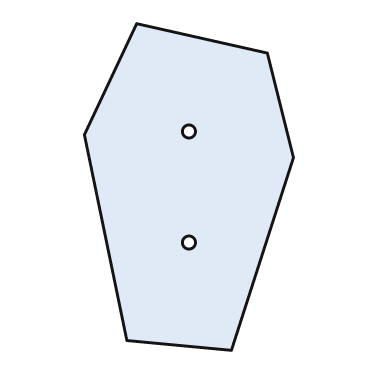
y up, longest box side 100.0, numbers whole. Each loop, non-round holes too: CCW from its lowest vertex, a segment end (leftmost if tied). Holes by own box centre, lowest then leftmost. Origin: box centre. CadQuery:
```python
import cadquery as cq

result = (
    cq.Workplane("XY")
    .moveTo(13.0, -50.0)
    .lineTo(32.0, 9.0)
    .lineTo(24.0, 41.0)
    .lineTo(-16.0, 50.0)
    .lineTo(-32.0, 16.0)
    .lineTo(-19.0, -47.0)
    .close()
    .moveTo(0.0, -17.0)
    .circle(2.0)
    .moveTo(0.0, 17.0)
    .circle(2.0)
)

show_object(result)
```